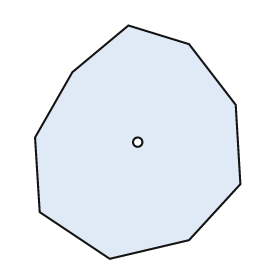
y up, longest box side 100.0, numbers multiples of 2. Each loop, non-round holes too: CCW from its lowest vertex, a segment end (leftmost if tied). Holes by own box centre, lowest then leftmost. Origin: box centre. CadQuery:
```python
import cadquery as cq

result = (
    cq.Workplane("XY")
    .moveTo(-12.0, -50.0)
    .lineTo(22.0, -42.0)
    .lineTo(44.0, -18.0)
    .lineTo(42.0, 16.0)
    .lineTo(22.0, 42.0)
    .lineTo(-4.0, 50.0)
    .lineTo(-28.0, 30.0)
    .lineTo(-44.0, 2.0)
    .lineTo(-42.0, -30.0)
    .close()
    .moveTo(0.0, 0.0)
    .circle(2.0)
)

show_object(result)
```